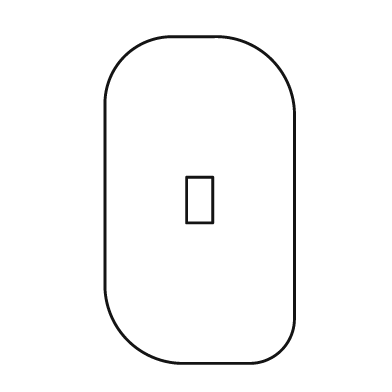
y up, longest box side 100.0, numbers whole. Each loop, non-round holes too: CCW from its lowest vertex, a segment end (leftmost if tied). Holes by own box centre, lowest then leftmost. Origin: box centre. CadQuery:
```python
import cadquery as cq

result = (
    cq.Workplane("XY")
    .moveTo(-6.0, -50.0)
    .lineTo(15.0, -50.0)
    .threePointArc((25.0, -46.0), (29.0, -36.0))
    .lineTo(29.0, 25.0)
    .threePointArc((22.0, 43.0), (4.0, 50.0))
    .lineTo(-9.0, 50.0)
    .threePointArc((-23.0, 44.0), (-29.0, 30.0))
    .lineTo(-29.0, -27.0)
    .threePointArc((-22.0, -43.0), (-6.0, -50.0))
    .close()
    .moveTo(-4.0, -7.0)
    .lineTo(4.0, -7.0)
    .lineTo(4.0, 7.0)
    .lineTo(-4.0, 7.0)
    .close()
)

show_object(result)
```